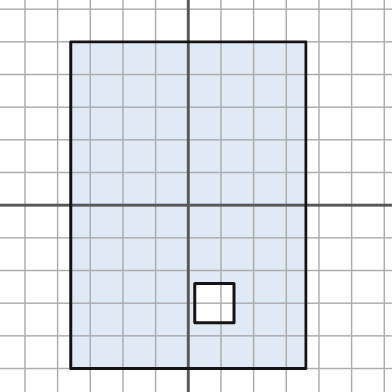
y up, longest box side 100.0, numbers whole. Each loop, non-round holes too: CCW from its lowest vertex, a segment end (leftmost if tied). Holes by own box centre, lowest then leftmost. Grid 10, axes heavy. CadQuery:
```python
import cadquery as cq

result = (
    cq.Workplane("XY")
    .moveTo(-36.0, -50.0)
    .lineTo(36.0, -50.0)
    .lineTo(36.0, 50.0)
    .lineTo(-36.0, 50.0)
    .close()
    .moveTo(2.0, -36.0)
    .lineTo(14.0, -36.0)
    .lineTo(14.0, -24.0)
    .lineTo(2.0, -24.0)
    .close()
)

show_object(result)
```